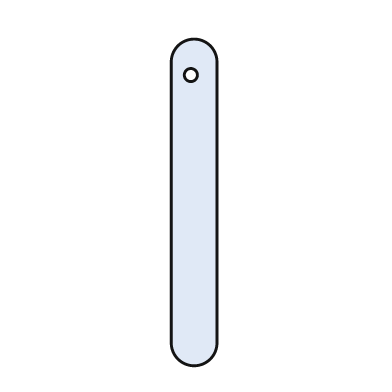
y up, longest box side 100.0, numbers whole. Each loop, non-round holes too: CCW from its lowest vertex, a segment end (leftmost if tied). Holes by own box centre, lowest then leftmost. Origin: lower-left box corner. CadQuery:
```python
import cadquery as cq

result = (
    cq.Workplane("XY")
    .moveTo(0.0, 7.0)
    .threePointArc((7.0, 0.0), (14.0, 7.0))
    .lineTo(14.0, 93.0)
    .threePointArc((7.0, 100.0), (0.0, 93.0))
    .close()
    .moveTo(6.0, 89.0)
    .circle(2.0)
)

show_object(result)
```